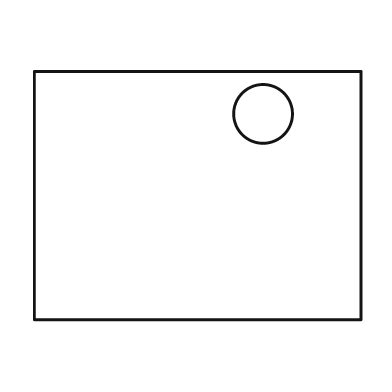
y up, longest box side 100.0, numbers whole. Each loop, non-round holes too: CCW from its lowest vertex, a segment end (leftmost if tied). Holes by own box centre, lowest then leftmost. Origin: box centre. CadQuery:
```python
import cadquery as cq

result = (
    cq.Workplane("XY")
    .moveTo(-50.0, -38.0)
    .lineTo(50.0, -38.0)
    .lineTo(50.0, 38.0)
    .lineTo(-50.0, 38.0)
    .close()
    .moveTo(20.0, 25.0)
    .circle(9.0)
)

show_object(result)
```